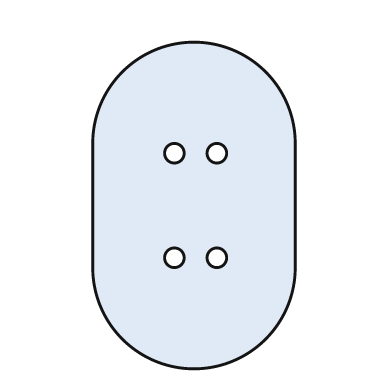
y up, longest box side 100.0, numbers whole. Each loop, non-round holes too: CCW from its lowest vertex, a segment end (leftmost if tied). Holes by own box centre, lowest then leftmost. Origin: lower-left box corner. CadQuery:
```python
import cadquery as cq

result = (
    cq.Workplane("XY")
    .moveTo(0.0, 31.0)
    .threePointArc((31.0, 0.0), (62.0, 31.0))
    .lineTo(62.0, 69.0)
    .threePointArc((31.0, 100.0), (0.0, 69.0))
    .close()
    .moveTo(25.0, 34.0)
    .circle(3.0)
    .moveTo(38.0, 34.0)
    .circle(3.0)
    .moveTo(25.0, 66.0)
    .circle(3.0)
    .moveTo(38.0, 66.0)
    .circle(3.0)
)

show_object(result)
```